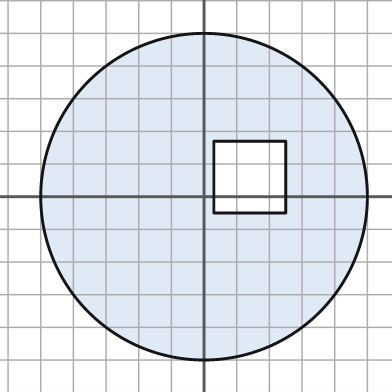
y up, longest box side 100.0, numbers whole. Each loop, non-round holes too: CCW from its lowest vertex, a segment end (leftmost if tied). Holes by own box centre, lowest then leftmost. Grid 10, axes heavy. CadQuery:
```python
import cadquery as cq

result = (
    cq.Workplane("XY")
    .moveTo(0.0, 0.0)
    .circle(50.0)
    .moveTo(3.0, -5.0)
    .lineTo(25.0, -5.0)
    .lineTo(25.0, 17.0)
    .lineTo(3.0, 17.0)
    .close()
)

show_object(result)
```